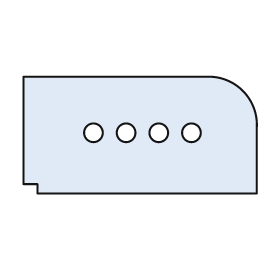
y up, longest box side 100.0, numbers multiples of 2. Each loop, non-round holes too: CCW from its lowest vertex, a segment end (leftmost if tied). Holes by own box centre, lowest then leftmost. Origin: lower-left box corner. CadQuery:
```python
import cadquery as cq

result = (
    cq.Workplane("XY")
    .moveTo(6.0, 0.0)
    .lineTo(100.0, 0.0)
    .lineTo(100.0, 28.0)
    .threePointArc((94.0, 44.0), (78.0, 50.0))
    .lineTo(0.0, 50.0)
    .lineTo(0.0, 4.0)
    .lineTo(6.0, 4.0)
    .close()
    .moveTo(30.0, 26.0)
    .circle(4.0)
    .moveTo(44.0, 26.0)
    .circle(4.0)
    .moveTo(58.0, 26.0)
    .circle(4.0)
    .moveTo(72.0, 26.0)
    .circle(4.0)
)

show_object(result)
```